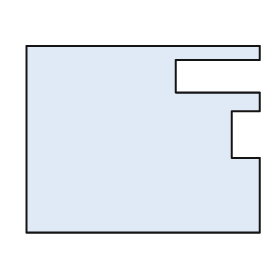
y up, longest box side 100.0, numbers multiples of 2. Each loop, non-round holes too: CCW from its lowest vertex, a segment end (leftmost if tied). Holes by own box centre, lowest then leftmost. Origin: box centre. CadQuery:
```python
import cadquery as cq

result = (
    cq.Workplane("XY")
    .moveTo(-50.0, -40.0)
    .lineTo(50.0, -40.0)
    .lineTo(50.0, -8.0)
    .lineTo(38.0, -8.0)
    .lineTo(38.0, 12.0)
    .lineTo(50.0, 12.0)
    .lineTo(50.0, 20.0)
    .lineTo(14.0, 20.0)
    .lineTo(14.0, 34.0)
    .lineTo(50.0, 34.0)
    .lineTo(50.0, 40.0)
    .lineTo(-50.0, 40.0)
    .close()
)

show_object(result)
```